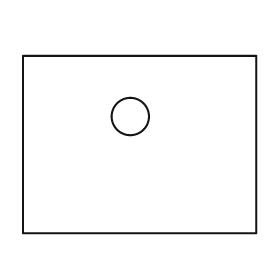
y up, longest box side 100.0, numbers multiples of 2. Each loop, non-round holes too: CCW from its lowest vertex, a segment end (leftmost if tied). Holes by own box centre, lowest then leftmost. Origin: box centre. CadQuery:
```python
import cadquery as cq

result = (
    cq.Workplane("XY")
    .moveTo(-50.0, -38.0)
    .lineTo(50.0, -38.0)
    .lineTo(50.0, 38.0)
    .lineTo(-50.0, 38.0)
    .close()
    .moveTo(-4.0, 12.0)
    .circle(8.0)
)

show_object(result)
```